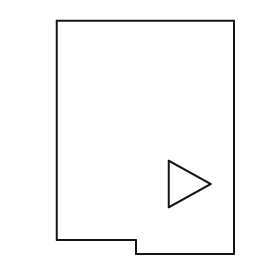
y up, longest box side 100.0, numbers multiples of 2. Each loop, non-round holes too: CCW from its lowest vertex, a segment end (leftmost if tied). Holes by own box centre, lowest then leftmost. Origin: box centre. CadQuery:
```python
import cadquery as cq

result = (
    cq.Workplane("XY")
    .moveTo(-4.0, -50.0)
    .lineTo(38.0, -50.0)
    .lineTo(38.0, 50.0)
    .lineTo(-38.0, 50.0)
    .lineTo(-38.0, -44.0)
    .lineTo(-4.0, -44.0)
    .close()
    .moveTo(10.0, -30.0)
    .lineTo(28.0, -20.0)
    .lineTo(10.0, -10.0)
    .close()
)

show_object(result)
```